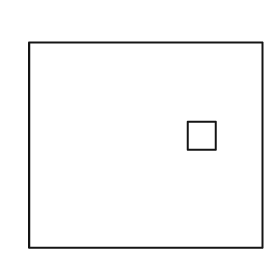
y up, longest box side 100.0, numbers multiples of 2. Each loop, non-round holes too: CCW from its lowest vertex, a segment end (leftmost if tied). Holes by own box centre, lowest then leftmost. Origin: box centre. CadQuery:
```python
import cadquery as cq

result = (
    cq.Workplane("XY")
    .moveTo(-50.0, -44.0)
    .lineTo(50.0, -44.0)
    .lineTo(50.0, 44.0)
    .lineTo(-50.0, 44.0)
    .close()
    .moveTo(18.0, -2.0)
    .lineTo(30.0, -2.0)
    .lineTo(30.0, 10.0)
    .lineTo(18.0, 10.0)
    .close()
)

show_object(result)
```